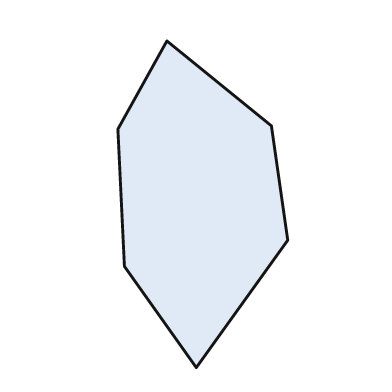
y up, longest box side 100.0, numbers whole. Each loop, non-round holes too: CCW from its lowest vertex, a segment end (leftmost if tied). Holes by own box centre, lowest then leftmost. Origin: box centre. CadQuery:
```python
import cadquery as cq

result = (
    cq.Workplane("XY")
    .moveTo(-2.0, -50.0)
    .lineTo(26.0, -11.0)
    .lineTo(21.0, 24.0)
    .lineTo(-11.0, 50.0)
    .lineTo(-26.0, 23.0)
    .lineTo(-24.0, -19.0)
    .close()
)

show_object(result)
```